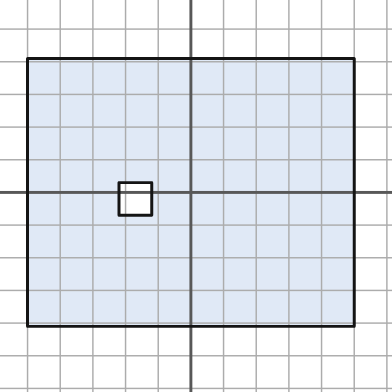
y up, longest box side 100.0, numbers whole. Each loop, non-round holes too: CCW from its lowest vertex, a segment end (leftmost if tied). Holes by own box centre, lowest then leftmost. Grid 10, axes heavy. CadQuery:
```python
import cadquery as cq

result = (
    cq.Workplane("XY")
    .moveTo(-50.0, -41.0)
    .lineTo(50.0, -41.0)
    .lineTo(50.0, 41.0)
    .lineTo(-50.0, 41.0)
    .close()
    .moveTo(-22.0, -7.0)
    .lineTo(-12.0, -7.0)
    .lineTo(-12.0, 3.0)
    .lineTo(-22.0, 3.0)
    .close()
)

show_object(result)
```